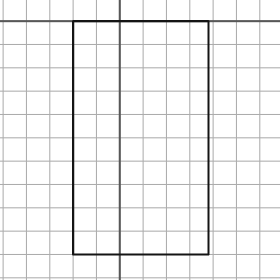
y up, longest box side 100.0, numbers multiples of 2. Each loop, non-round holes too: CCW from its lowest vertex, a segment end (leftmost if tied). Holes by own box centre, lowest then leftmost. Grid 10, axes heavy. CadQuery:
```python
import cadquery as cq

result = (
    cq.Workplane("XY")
    .moveTo(-20.0, -100.0)
    .lineTo(38.0, -100.0)
    .lineTo(38.0, 0.0)
    .lineTo(-20.0, 0.0)
    .close()
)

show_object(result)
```